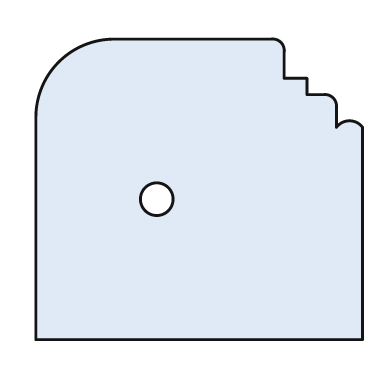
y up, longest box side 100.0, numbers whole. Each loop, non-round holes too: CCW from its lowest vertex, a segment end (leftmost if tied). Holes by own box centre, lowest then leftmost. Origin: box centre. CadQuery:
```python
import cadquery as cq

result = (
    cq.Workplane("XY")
    .moveTo(-50.0, -46.0)
    .lineTo(50.0, -46.0)
    .lineTo(50.0, 19.0)
    .threePointArc((46.0, 21.0), (42.0, 19.0))
    .lineTo(42.0, 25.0)
    .threePointArc((41.0, 28.0), (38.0, 29.0))
    .lineTo(33.0, 29.0)
    .lineTo(33.0, 34.0)
    .lineTo(26.0, 34.0)
    .lineTo(26.0, 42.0)
    .threePointArc((25.0, 45.0), (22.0, 46.0))
    .lineTo(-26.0, 46.0)
    .threePointArc((-43.0, 39.0), (-50.0, 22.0))
    .close()
    .moveTo(-13.0, -3.0)
    .circle(5.0)
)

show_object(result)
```